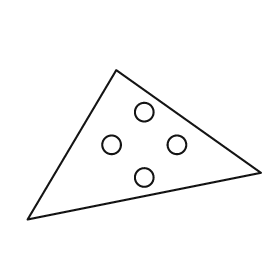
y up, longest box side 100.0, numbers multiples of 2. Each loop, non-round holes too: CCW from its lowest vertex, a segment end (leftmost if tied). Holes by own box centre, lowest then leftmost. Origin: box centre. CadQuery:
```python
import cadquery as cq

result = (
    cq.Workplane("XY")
    .moveTo(-50.0, -32.0)
    .lineTo(50.0, -12.0)
    .lineTo(-12.0, 32.0)
    .close()
    .moveTo(0.0, -14.0)
    .circle(4.0)
    .moveTo(-14.0, 0.0)
    .circle(4.0)
    .moveTo(14.0, 0.0)
    .circle(4.0)
    .moveTo(0.0, 14.0)
    .circle(4.0)
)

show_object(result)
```